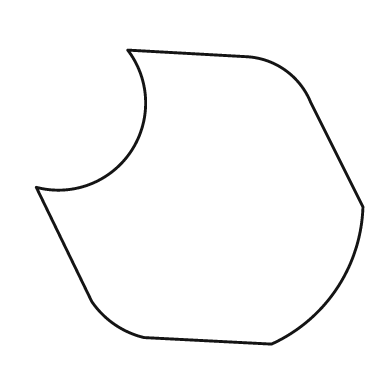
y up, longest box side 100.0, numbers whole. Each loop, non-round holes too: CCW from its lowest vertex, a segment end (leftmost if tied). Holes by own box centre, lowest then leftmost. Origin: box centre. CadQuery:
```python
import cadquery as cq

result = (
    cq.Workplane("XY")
    .moveTo(22.0, -45.0)
    .threePointArc((42.0, -28.0), (50.0, -3.0))
    .lineTo(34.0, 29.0)
    .threePointArc((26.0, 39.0), (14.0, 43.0))
    .lineTo(-22.0, 45.0)
    .threePointArc((-21.0, 14.0), (-50.0, 3.0))
    .lineTo(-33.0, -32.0)
    .threePointArc((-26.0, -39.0), (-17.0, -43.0))
    .close()
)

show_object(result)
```